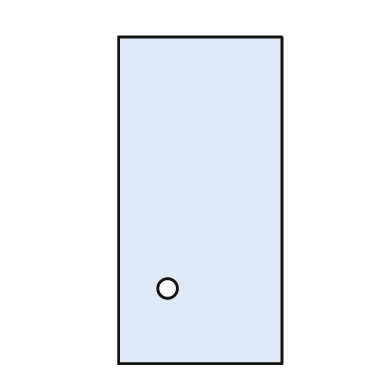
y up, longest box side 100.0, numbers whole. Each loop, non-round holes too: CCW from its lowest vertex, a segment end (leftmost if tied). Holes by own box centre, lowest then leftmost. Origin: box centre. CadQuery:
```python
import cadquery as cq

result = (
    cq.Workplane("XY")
    .moveTo(-25.0, -50.0)
    .lineTo(25.0, -50.0)
    .lineTo(25.0, 50.0)
    .lineTo(-25.0, 50.0)
    .close()
    .moveTo(-10.0, -27.0)
    .circle(3.0)
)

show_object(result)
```